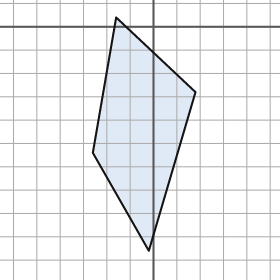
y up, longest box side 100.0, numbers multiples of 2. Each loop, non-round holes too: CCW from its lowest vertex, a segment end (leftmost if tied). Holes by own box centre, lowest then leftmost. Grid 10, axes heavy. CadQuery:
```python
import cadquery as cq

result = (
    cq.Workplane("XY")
    .moveTo(-2.0, -96.0)
    .lineTo(18.0, -28.0)
    .lineTo(-16.0, 4.0)
    .lineTo(-26.0, -54.0)
    .close()
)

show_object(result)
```